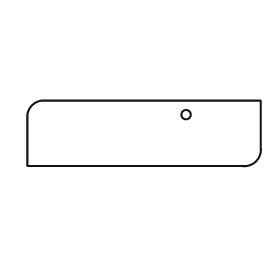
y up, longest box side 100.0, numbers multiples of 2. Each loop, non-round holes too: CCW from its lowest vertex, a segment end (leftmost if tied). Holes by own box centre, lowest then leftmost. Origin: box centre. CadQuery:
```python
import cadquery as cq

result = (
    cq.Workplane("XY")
    .moveTo(-50.0, -14.0)
    .lineTo(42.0, -14.0)
    .threePointArc((48.0, -12.0), (50.0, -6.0))
    .lineTo(50.0, 14.0)
    .lineTo(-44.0, 14.0)
    .threePointArc((-48.0, 12.0), (-50.0, 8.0))
    .close()
    .moveTo(18.0, 8.0)
    .circle(2.0)
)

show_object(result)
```